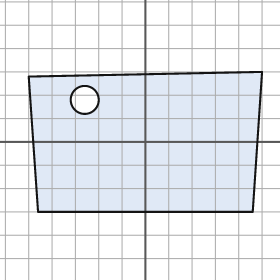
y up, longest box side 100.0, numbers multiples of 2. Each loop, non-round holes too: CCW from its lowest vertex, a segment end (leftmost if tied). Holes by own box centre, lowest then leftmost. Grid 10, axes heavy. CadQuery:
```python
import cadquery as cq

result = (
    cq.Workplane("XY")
    .moveTo(-46.0, -30.0)
    .lineTo(46.0, -30.0)
    .lineTo(50.0, 30.0)
    .lineTo(-50.0, 28.0)
    .close()
    .moveTo(-26.0, 18.0)
    .circle(6.0)
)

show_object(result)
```